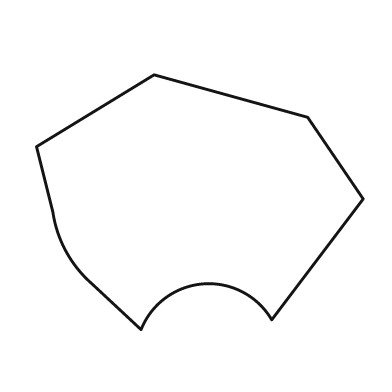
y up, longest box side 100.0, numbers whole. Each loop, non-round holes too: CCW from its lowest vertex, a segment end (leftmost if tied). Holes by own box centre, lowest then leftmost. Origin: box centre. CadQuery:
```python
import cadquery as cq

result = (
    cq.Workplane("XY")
    .moveTo(-18.0, -39.0)
    .threePointArc((1.0, -25.0), (22.0, -36.0))
    .lineTo(50.0, 1.0)
    .lineTo(33.0, 26.0)
    .lineTo(-14.0, 39.0)
    .lineTo(-50.0, 17.0)
    .lineTo(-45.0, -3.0)
    .threePointArc((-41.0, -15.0), (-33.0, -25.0))
    .close()
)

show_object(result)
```